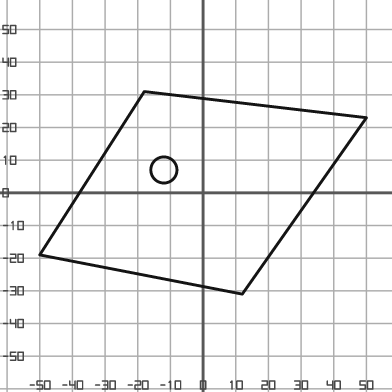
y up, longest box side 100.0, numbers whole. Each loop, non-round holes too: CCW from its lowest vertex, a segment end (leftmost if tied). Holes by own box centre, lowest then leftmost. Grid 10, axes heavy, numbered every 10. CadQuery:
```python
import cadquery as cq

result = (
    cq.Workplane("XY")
    .moveTo(12.0, -31.0)
    .lineTo(50.0, 23.0)
    .lineTo(-18.0, 31.0)
    .lineTo(-50.0, -19.0)
    .close()
    .moveTo(-12.0, 7.0)
    .circle(4.0)
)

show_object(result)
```